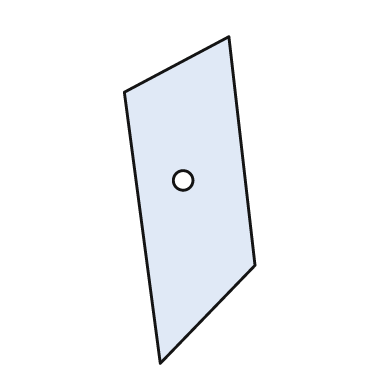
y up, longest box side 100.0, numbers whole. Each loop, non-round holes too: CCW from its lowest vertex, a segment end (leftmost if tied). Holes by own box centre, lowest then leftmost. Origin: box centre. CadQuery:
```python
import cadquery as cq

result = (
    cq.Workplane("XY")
    .moveTo(-9.0, -50.0)
    .lineTo(20.0, -20.0)
    .lineTo(12.0, 50.0)
    .lineTo(-20.0, 33.0)
    .close()
    .moveTo(-2.0, 6.0)
    .circle(3.0)
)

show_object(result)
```